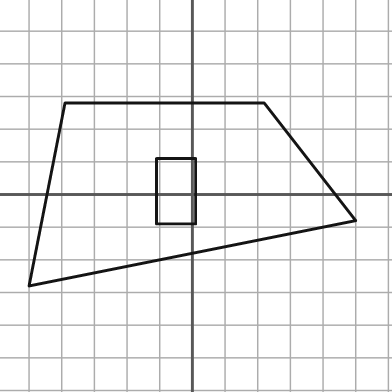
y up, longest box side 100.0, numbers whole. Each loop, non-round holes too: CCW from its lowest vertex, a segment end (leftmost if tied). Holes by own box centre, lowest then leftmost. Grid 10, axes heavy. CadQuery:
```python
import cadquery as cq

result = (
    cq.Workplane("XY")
    .moveTo(-50.0, -28.0)
    .lineTo(50.0, -8.0)
    .lineTo(22.0, 28.0)
    .lineTo(-39.0, 28.0)
    .close()
    .moveTo(-11.0, -9.0)
    .lineTo(1.0, -9.0)
    .lineTo(1.0, 11.0)
    .lineTo(-11.0, 11.0)
    .close()
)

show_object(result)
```